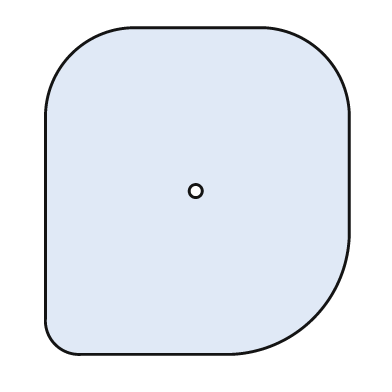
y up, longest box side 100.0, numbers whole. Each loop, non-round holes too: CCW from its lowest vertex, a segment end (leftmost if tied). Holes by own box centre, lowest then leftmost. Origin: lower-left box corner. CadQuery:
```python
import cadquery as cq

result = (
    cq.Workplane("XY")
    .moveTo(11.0, 0.0)
    .lineTo(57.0, 0.0)
    .threePointArc((82.0, 11.0), (93.0, 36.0))
    .lineTo(93.0, 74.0)
    .threePointArc((85.0, 92.0), (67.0, 100.0))
    .lineTo(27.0, 100.0)
    .threePointArc((8.0, 92.0), (0.0, 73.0))
    .lineTo(0.0, 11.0)
    .threePointArc((3.0, 3.0), (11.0, 0.0))
    .close()
    .moveTo(46.0, 50.0)
    .circle(2.0)
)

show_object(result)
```